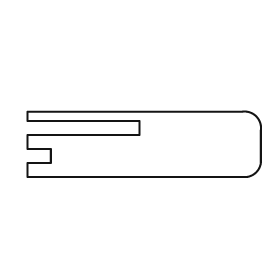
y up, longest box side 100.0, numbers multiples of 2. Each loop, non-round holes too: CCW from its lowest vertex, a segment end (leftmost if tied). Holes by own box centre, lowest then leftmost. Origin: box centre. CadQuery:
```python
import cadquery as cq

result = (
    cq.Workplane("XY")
    .moveTo(-50.0, -14.0)
    .lineTo(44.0, -14.0)
    .threePointArc((48.0, -12.0), (50.0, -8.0))
    .lineTo(50.0, 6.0)
    .threePointArc((48.0, 12.0), (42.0, 14.0))
    .lineTo(-50.0, 14.0)
    .lineTo(-50.0, 10.0)
    .lineTo(-2.0, 10.0)
    .lineTo(-2.0, 4.0)
    .lineTo(-50.0, 4.0)
    .lineTo(-50.0, -2.0)
    .lineTo(-40.0, -2.0)
    .lineTo(-40.0, -8.0)
    .lineTo(-50.0, -8.0)
    .close()
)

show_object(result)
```